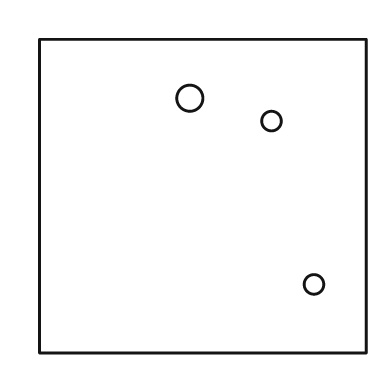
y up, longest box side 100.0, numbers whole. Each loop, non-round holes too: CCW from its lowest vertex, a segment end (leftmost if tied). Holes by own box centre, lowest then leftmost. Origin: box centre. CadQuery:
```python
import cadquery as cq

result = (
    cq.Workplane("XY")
    .moveTo(-50.0, -48.0)
    .lineTo(50.0, -48.0)
    .lineTo(50.0, 48.0)
    .lineTo(-50.0, 48.0)
    .close()
    .moveTo(34.0, -27.0)
    .circle(3.0)
    .moveTo(21.0, 23.0)
    .circle(3.0)
    .moveTo(-4.0, 30.0)
    .circle(4.0)
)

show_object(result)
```